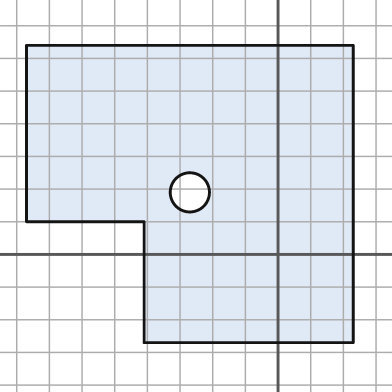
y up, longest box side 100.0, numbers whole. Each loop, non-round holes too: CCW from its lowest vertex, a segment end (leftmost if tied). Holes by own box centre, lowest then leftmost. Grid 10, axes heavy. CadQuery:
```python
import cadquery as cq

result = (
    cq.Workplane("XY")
    .moveTo(-41.0, -27.0)
    .lineTo(23.0, -27.0)
    .lineTo(23.0, 64.0)
    .lineTo(-77.0, 64.0)
    .lineTo(-77.0, 10.0)
    .lineTo(-41.0, 10.0)
    .close()
    .moveTo(-27.0, 19.0)
    .circle(6.0)
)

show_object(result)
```